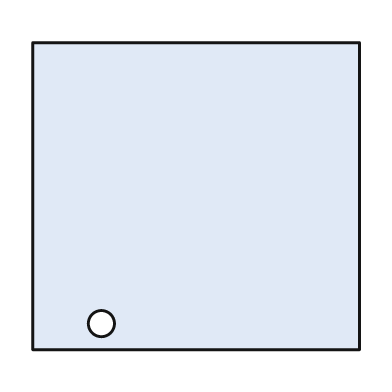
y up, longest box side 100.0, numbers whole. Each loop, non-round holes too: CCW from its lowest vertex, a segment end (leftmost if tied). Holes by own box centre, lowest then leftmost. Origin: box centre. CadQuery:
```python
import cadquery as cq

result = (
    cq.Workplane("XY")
    .moveTo(-50.0, -47.0)
    .lineTo(50.0, -47.0)
    .lineTo(50.0, 47.0)
    .lineTo(-50.0, 47.0)
    .close()
    .moveTo(-29.0, -39.0)
    .circle(4.0)
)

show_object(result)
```